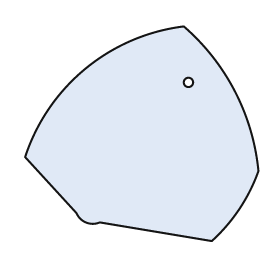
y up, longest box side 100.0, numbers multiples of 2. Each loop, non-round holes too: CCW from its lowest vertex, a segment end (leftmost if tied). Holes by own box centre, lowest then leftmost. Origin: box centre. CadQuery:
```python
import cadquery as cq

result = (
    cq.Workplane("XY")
    .moveTo(30.0, -46.0)
    .threePointArc((42.0, -32.0), (50.0, -16.0))
    .threePointArc((40.0, 18.0), (18.0, 46.0))
    .threePointArc((-24.0, 28.0), (-50.0, -10.0))
    .lineTo(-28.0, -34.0)
    .threePointArc((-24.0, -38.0), (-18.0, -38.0))
    .close()
    .moveTo(20.0, 22.0)
    .circle(2.0)
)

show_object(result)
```